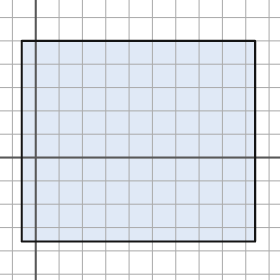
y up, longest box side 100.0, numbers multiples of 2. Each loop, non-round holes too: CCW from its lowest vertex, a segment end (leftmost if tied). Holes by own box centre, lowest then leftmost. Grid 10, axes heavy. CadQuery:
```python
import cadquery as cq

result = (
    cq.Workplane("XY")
    .moveTo(-6.0, -36.0)
    .lineTo(94.0, -36.0)
    .lineTo(94.0, 50.0)
    .lineTo(-6.0, 50.0)
    .close()
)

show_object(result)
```